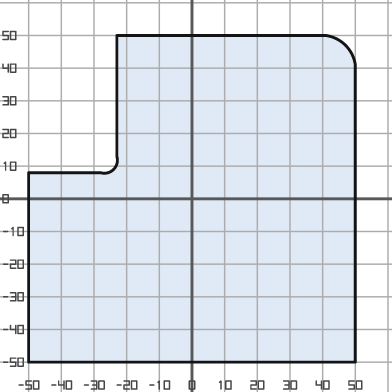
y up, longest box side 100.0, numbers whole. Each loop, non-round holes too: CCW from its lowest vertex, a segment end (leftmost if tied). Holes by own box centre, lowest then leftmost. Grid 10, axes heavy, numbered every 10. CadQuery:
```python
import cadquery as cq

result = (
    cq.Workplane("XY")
    .moveTo(-50.0, -50.0)
    .lineTo(50.0, -50.0)
    .lineTo(50.0, 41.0)
    .threePointArc((47.0, 47.0), (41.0, 50.0))
    .lineTo(-23.0, 50.0)
    .lineTo(-23.0, 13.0)
    .threePointArc((-24.0, 9.0), (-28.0, 8.0))
    .lineTo(-50.0, 8.0)
    .close()
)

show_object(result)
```